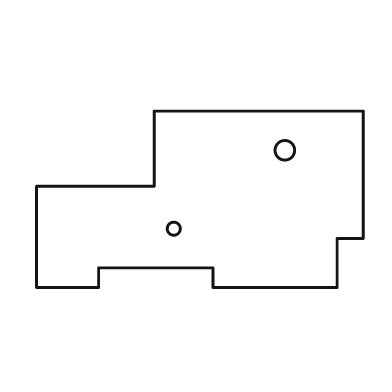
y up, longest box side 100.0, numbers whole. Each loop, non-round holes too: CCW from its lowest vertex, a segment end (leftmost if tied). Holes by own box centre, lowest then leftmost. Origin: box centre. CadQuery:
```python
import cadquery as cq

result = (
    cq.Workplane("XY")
    .moveTo(-50.0, -27.0)
    .lineTo(-31.0, -27.0)
    .lineTo(-31.0, -21.0)
    .lineTo(4.0, -21.0)
    .lineTo(4.0, -27.0)
    .lineTo(42.0, -27.0)
    .lineTo(42.0, -12.0)
    .lineTo(50.0, -12.0)
    .lineTo(50.0, 27.0)
    .lineTo(-14.0, 27.0)
    .lineTo(-14.0, 4.0)
    .lineTo(-50.0, 4.0)
    .close()
    .moveTo(-8.0, -9.0)
    .circle(2.0)
    .moveTo(26.0, 15.0)
    .circle(3.0)
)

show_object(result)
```